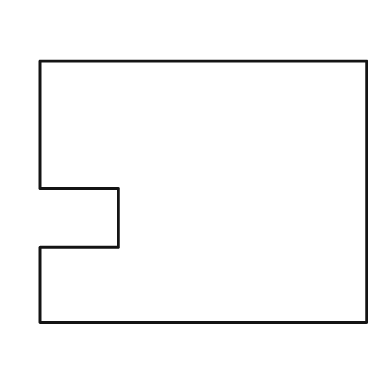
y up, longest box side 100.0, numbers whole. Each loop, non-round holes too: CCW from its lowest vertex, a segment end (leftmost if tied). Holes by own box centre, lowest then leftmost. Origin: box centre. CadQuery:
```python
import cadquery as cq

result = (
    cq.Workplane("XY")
    .moveTo(-50.0, -40.0)
    .lineTo(50.0, -40.0)
    .lineTo(50.0, 40.0)
    .lineTo(-50.0, 40.0)
    .lineTo(-50.0, 1.0)
    .lineTo(-26.0, 1.0)
    .lineTo(-26.0, -17.0)
    .lineTo(-50.0, -17.0)
    .close()
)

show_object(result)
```